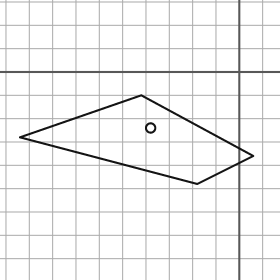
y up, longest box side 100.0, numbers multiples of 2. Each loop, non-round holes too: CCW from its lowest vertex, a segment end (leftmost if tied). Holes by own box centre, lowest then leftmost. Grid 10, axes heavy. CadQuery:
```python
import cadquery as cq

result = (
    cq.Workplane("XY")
    .moveTo(-18.0, -48.0)
    .lineTo(6.0, -36.0)
    .lineTo(-42.0, -10.0)
    .lineTo(-94.0, -28.0)
    .close()
    .moveTo(-38.0, -24.0)
    .circle(2.0)
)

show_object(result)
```